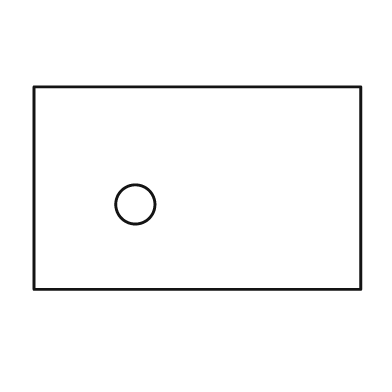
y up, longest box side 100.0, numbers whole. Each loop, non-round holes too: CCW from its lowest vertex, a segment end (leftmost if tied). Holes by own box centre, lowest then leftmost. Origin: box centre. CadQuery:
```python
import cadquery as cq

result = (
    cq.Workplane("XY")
    .moveTo(-50.0, -31.0)
    .lineTo(50.0, -31.0)
    .lineTo(50.0, 31.0)
    .lineTo(-50.0, 31.0)
    .close()
    .moveTo(-19.0, -5.0)
    .circle(6.0)
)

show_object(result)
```